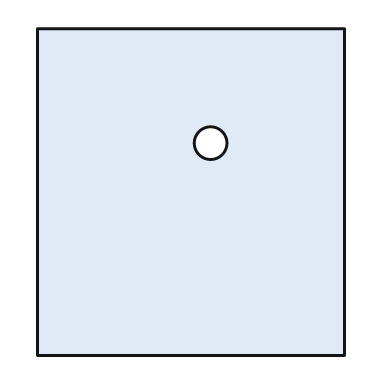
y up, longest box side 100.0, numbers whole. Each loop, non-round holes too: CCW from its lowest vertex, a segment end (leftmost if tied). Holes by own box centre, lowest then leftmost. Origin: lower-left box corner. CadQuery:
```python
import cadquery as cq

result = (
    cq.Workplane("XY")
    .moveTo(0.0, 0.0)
    .lineTo(94.0, 0.0)
    .lineTo(94.0, 100.0)
    .lineTo(0.0, 100.0)
    .close()
    .moveTo(53.0, 65.0)
    .circle(5.0)
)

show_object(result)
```